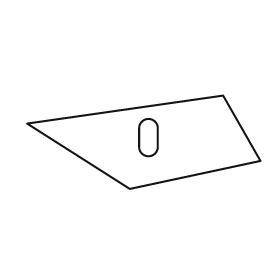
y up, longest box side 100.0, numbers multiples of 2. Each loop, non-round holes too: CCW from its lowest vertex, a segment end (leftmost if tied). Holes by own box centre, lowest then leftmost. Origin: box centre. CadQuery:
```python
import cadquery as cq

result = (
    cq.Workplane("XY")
    .moveTo(-6.0, -20.0)
    .lineTo(50.0, -8.0)
    .lineTo(34.0, 20.0)
    .lineTo(-50.0, 8.0)
    .close()
    .moveTo(-2.0, -2.0)
    .threePointArc((2.0, -6.0), (6.0, -2.0))
    .lineTo(6.0, 6.0)
    .threePointArc((2.0, 10.0), (-2.0, 6.0))
    .close()
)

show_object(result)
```